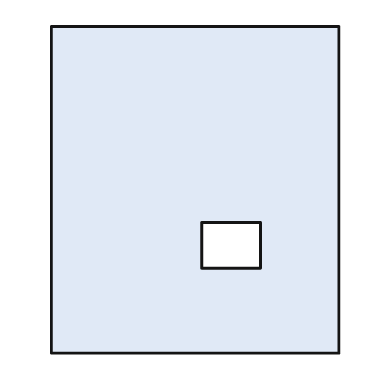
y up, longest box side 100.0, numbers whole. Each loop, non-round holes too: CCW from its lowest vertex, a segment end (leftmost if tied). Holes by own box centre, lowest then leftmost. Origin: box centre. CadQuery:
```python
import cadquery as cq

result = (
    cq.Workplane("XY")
    .moveTo(-44.0, -50.0)
    .lineTo(44.0, -50.0)
    .lineTo(44.0, 50.0)
    .lineTo(-44.0, 50.0)
    .close()
    .moveTo(2.0, -24.0)
    .lineTo(20.0, -24.0)
    .lineTo(20.0, -10.0)
    .lineTo(2.0, -10.0)
    .close()
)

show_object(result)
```